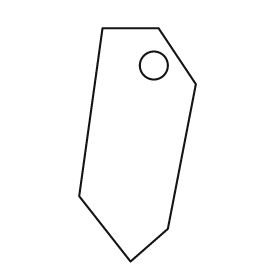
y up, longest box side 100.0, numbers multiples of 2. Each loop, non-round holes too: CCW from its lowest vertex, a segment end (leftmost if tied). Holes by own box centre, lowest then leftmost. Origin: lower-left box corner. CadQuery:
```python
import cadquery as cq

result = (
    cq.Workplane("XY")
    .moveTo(22.0, 0.0)
    .lineTo(38.0, 14.0)
    .lineTo(50.0, 76.0)
    .lineTo(34.0, 100.0)
    .lineTo(10.0, 100.0)
    .lineTo(0.0, 28.0)
    .close()
    .moveTo(32.0, 84.0)
    .circle(6.0)
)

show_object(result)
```